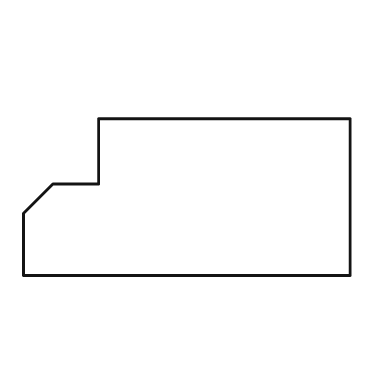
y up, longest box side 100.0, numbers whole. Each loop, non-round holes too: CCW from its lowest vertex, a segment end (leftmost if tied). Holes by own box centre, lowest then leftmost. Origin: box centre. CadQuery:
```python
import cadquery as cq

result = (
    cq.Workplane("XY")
    .moveTo(-50.0, -24.0)
    .lineTo(50.0, -24.0)
    .lineTo(50.0, 24.0)
    .lineTo(-27.0, 24.0)
    .lineTo(-27.0, 4.0)
    .lineTo(-41.0, 4.0)
    .lineTo(-50.0, -5.0)
    .close()
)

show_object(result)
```